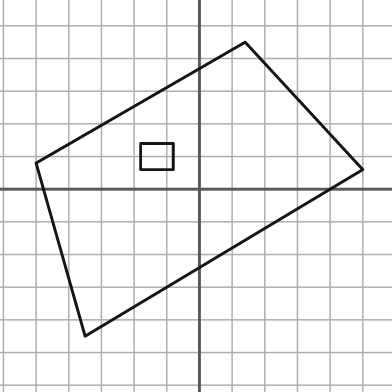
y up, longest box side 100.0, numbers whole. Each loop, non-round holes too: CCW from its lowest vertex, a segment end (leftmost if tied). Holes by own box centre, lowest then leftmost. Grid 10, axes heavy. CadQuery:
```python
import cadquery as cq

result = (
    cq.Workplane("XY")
    .moveTo(-35.0, -45.0)
    .lineTo(50.0, 6.0)
    .lineTo(14.0, 45.0)
    .lineTo(-50.0, 8.0)
    .close()
    .moveTo(-18.0, 6.0)
    .lineTo(-8.0, 6.0)
    .lineTo(-8.0, 14.0)
    .lineTo(-18.0, 14.0)
    .close()
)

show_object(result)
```